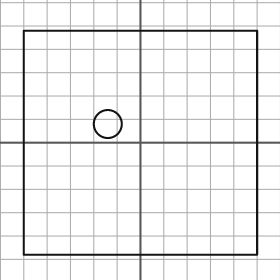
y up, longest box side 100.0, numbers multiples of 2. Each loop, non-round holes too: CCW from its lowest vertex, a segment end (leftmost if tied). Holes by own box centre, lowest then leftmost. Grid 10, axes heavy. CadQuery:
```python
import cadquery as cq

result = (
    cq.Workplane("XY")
    .moveTo(-50.0, -48.0)
    .lineTo(50.0, -48.0)
    .lineTo(50.0, 48.0)
    .lineTo(-50.0, 48.0)
    .close()
    .moveTo(-14.0, 8.0)
    .circle(6.0)
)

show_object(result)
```